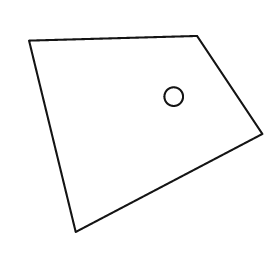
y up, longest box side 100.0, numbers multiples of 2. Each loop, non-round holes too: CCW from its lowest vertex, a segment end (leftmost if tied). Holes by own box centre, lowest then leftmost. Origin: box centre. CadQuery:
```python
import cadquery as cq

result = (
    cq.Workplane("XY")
    .moveTo(-30.0, -42.0)
    .lineTo(50.0, 0.0)
    .lineTo(22.0, 42.0)
    .lineTo(-50.0, 40.0)
    .close()
    .moveTo(12.0, 16.0)
    .circle(4.0)
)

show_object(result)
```